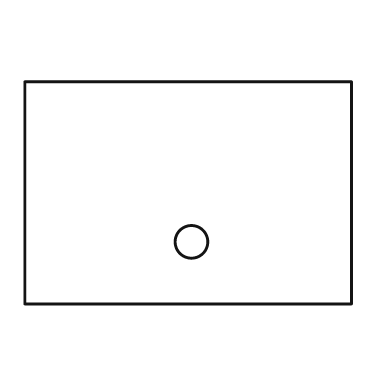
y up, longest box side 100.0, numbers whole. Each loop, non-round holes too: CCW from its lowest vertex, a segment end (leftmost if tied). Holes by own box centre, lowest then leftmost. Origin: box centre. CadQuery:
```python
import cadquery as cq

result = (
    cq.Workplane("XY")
    .moveTo(-50.0, -34.0)
    .lineTo(50.0, -34.0)
    .lineTo(50.0, 34.0)
    .lineTo(-50.0, 34.0)
    .close()
    .moveTo(1.0, -15.0)
    .circle(5.0)
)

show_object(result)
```